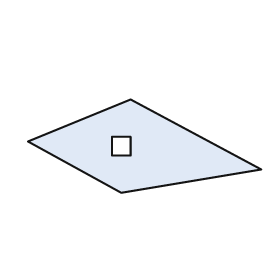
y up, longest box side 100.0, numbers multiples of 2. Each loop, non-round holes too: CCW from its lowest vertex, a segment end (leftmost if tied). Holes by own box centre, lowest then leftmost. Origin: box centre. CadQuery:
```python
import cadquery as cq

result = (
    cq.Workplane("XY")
    .moveTo(-10.0, -20.0)
    .lineTo(50.0, -10.0)
    .lineTo(-6.0, 20.0)
    .lineTo(-50.0, 2.0)
    .close()
    .moveTo(-14.0, -4.0)
    .lineTo(-6.0, -4.0)
    .lineTo(-6.0, 4.0)
    .lineTo(-14.0, 4.0)
    .close()
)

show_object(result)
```